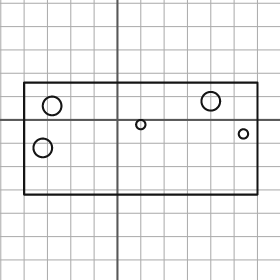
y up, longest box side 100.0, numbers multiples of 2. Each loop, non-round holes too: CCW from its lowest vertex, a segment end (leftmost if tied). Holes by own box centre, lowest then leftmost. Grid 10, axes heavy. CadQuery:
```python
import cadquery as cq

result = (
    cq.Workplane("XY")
    .moveTo(-40.0, -32.0)
    .lineTo(60.0, -32.0)
    .lineTo(60.0, 16.0)
    .lineTo(-40.0, 16.0)
    .close()
    .moveTo(-32.0, -12.0)
    .circle(4.0)
    .moveTo(54.0, -6.0)
    .circle(2.0)
    .moveTo(10.0, -2.0)
    .circle(2.0)
    .moveTo(-28.0, 6.0)
    .circle(4.0)
    .moveTo(40.0, 8.0)
    .circle(4.0)
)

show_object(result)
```